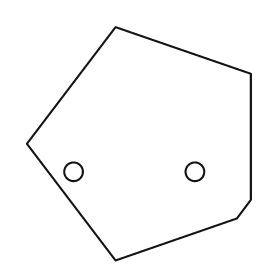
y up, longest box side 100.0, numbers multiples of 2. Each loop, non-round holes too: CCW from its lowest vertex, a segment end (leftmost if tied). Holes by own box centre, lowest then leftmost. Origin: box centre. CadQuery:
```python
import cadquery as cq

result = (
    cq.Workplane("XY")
    .moveTo(-10.0, -50.0)
    .lineTo(42.0, -32.0)
    .lineTo(48.0, -24.0)
    .lineTo(48.0, 30.0)
    .lineTo(-10.0, 50.0)
    .lineTo(-48.0, 0.0)
    .close()
    .moveTo(-28.0, -12.0)
    .circle(4.0)
    .moveTo(24.0, -12.0)
    .circle(4.0)
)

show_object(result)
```